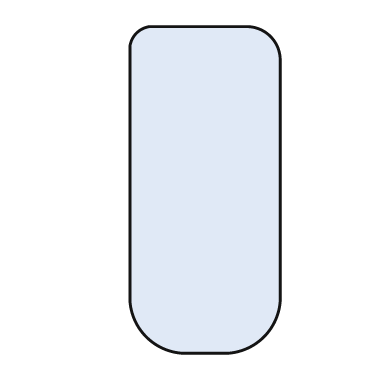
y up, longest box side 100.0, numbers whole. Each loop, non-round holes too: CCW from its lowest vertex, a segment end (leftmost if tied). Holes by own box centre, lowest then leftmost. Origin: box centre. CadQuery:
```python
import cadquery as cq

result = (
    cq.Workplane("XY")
    .moveTo(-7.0, -50.0)
    .lineTo(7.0, -50.0)
    .threePointArc((18.0, -45.0), (23.0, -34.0))
    .lineTo(23.0, 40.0)
    .threePointArc((20.0, 47.0), (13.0, 50.0))
    .lineTo(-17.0, 50.0)
    .threePointArc((-21.0, 48.0), (-23.0, 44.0))
    .lineTo(-23.0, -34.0)
    .threePointArc((-18.0, -45.0), (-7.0, -50.0))
    .close()
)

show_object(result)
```